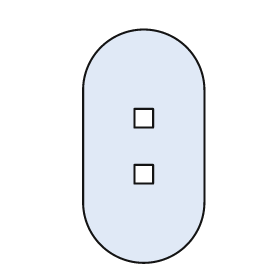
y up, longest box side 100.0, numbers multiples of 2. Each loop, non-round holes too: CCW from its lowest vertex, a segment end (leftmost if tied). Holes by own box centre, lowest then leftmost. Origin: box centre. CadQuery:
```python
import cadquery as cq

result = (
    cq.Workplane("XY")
    .moveTo(-26.0, -24.0)
    .threePointArc((0.0, -50.0), (26.0, -24.0))
    .lineTo(26.0, 24.0)
    .threePointArc((0.0, 50.0), (-26.0, 24.0))
    .close()
    .moveTo(-4.0, -16.0)
    .lineTo(4.0, -16.0)
    .lineTo(4.0, -8.0)
    .lineTo(-4.0, -8.0)
    .close()
    .moveTo(-4.0, 8.0)
    .lineTo(4.0, 8.0)
    .lineTo(4.0, 16.0)
    .lineTo(-4.0, 16.0)
    .close()
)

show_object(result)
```